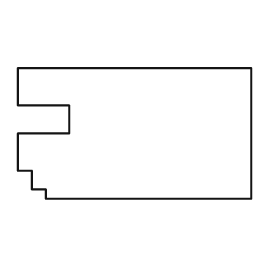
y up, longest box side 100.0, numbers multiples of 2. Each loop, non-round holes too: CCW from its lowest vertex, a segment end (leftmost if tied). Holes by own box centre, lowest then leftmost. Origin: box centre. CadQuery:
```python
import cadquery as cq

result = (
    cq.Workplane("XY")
    .moveTo(-38.0, -28.0)
    .lineTo(50.0, -28.0)
    .lineTo(50.0, 28.0)
    .lineTo(-50.0, 28.0)
    .lineTo(-50.0, 12.0)
    .lineTo(-28.0, 12.0)
    .lineTo(-28.0, 0.0)
    .lineTo(-50.0, 0.0)
    .lineTo(-50.0, -16.0)
    .lineTo(-44.0, -16.0)
    .lineTo(-44.0, -24.0)
    .lineTo(-38.0, -24.0)
    .close()
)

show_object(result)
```